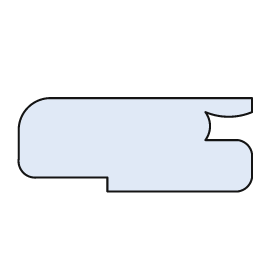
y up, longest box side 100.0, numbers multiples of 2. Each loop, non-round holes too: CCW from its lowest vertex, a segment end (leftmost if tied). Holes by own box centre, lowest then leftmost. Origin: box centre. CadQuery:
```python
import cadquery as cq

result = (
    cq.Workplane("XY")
    .moveTo(-12.0, -20.0)
    .lineTo(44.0, -20.0)
    .threePointArc((48.0, -18.0), (50.0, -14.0))
    .lineTo(50.0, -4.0)
    .threePointArc((48.0, 0.0), (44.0, 2.0))
    .lineTo(30.0, 2.0)
    .threePointArc((32.0, 8.0), (30.0, 14.0))
    .threePointArc((40.0, 12.0), (50.0, 14.0))
    .lineTo(50.0, 20.0)
    .lineTo(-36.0, 20.0)
    .threePointArc((-46.0, 16.0), (-50.0, 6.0))
    .lineTo(-50.0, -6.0)
    .threePointArc((-48.0, -12.0), (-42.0, -14.0))
    .lineTo(-12.0, -14.0)
    .close()
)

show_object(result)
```